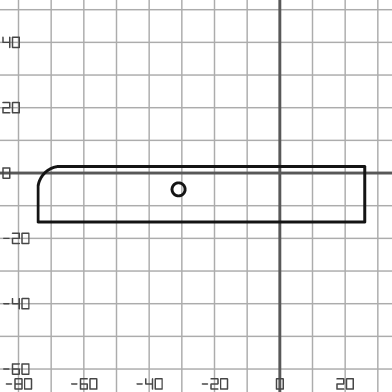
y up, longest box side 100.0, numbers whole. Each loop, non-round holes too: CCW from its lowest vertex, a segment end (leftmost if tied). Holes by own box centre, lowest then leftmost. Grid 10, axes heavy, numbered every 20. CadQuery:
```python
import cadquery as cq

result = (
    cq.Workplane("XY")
    .moveTo(-74.0, -15.0)
    .lineTo(26.0, -15.0)
    .lineTo(26.0, 2.0)
    .lineTo(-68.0, 2.0)
    .threePointArc((-72.0, 0.0), (-74.0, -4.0))
    .close()
    .moveTo(-31.0, -5.0)
    .circle(2.0)
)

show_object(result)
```